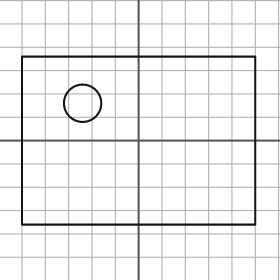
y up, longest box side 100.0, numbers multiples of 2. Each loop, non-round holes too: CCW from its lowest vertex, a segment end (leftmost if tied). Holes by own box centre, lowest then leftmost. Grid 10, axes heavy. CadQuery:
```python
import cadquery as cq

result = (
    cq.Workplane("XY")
    .moveTo(-50.0, -36.0)
    .lineTo(50.0, -36.0)
    .lineTo(50.0, 36.0)
    .lineTo(-50.0, 36.0)
    .close()
    .moveTo(-24.0, 16.0)
    .circle(8.0)
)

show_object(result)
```